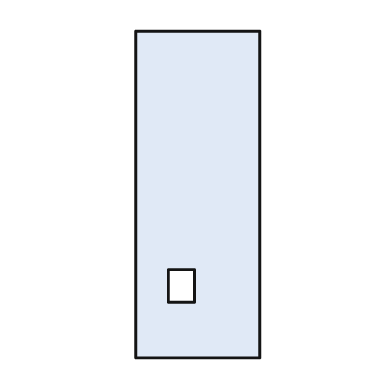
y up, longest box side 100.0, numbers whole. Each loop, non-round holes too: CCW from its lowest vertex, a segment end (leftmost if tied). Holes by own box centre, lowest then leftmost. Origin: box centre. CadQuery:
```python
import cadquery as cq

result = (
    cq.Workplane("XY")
    .moveTo(-19.0, -50.0)
    .lineTo(19.0, -50.0)
    .lineTo(19.0, 50.0)
    .lineTo(-19.0, 50.0)
    .close()
    .moveTo(-9.0, -33.0)
    .lineTo(-1.0, -33.0)
    .lineTo(-1.0, -23.0)
    .lineTo(-9.0, -23.0)
    .close()
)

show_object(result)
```